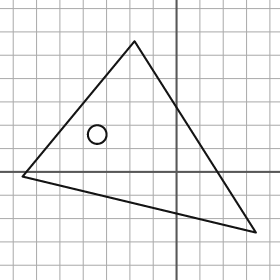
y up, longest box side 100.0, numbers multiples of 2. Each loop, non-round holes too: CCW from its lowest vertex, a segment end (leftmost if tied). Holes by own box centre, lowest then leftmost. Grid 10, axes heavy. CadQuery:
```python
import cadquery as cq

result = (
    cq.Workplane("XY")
    .moveTo(34.0, -26.0)
    .lineTo(-18.0, 56.0)
    .lineTo(-66.0, -2.0)
    .close()
    .moveTo(-34.0, 16.0)
    .circle(4.0)
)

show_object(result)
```